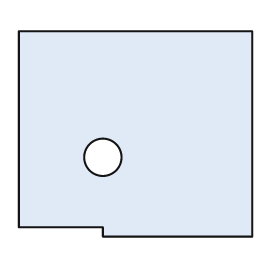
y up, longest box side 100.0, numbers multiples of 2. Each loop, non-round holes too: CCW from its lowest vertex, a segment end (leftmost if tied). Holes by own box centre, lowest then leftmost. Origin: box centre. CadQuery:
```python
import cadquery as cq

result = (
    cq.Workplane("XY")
    .moveTo(-14.0, -44.0)
    .lineTo(50.0, -44.0)
    .lineTo(50.0, 44.0)
    .lineTo(-50.0, 44.0)
    .lineTo(-50.0, -40.0)
    .lineTo(-14.0, -40.0)
    .close()
    .moveTo(-14.0, -10.0)
    .circle(8.0)
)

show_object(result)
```